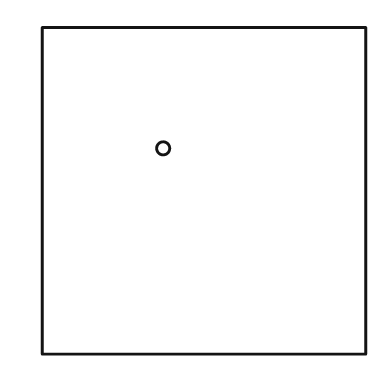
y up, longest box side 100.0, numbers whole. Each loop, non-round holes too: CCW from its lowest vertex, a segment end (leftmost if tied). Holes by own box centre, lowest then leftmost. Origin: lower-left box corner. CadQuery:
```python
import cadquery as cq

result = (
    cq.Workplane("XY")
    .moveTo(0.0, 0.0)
    .lineTo(99.0, 0.0)
    .lineTo(99.0, 100.0)
    .lineTo(0.0, 100.0)
    .close()
    .moveTo(37.0, 63.0)
    .circle(2.0)
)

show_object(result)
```